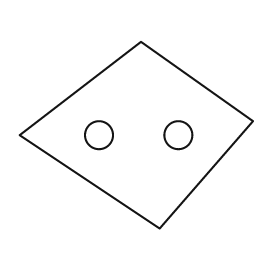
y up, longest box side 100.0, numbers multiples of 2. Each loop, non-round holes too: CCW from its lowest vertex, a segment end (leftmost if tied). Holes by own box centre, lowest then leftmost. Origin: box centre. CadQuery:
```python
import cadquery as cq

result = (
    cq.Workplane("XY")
    .moveTo(10.0, -40.0)
    .lineTo(50.0, 6.0)
    .lineTo(2.0, 40.0)
    .lineTo(-50.0, 0.0)
    .close()
    .moveTo(-16.0, 0.0)
    .circle(6.0)
    .moveTo(18.0, 0.0)
    .circle(6.0)
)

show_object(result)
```